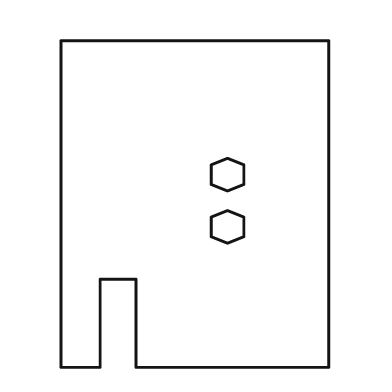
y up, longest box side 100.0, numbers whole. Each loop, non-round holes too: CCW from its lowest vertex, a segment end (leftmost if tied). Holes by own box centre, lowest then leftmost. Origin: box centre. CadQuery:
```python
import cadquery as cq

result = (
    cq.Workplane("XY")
    .moveTo(-41.0, -50.0)
    .lineTo(-29.0, -50.0)
    .lineTo(-29.0, -23.0)
    .lineTo(-18.0, -23.0)
    .lineTo(-18.0, -50.0)
    .lineTo(41.0, -50.0)
    .lineTo(41.0, 50.0)
    .lineTo(-41.0, 50.0)
    .close()
    .moveTo(10.0, -12.0)
    .lineTo(15.0, -10.0)
    .lineTo(15.0, -4.0)
    .lineTo(10.0, -2.0)
    .lineTo(5.0, -4.0)
    .lineTo(5.0, -10.0)
    .close()
    .moveTo(10.0, 4.0)
    .lineTo(15.0, 6.0)
    .lineTo(15.0, 12.0)
    .lineTo(10.0, 14.0)
    .lineTo(5.0, 12.0)
    .lineTo(5.0, 6.0)
    .close()
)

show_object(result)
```